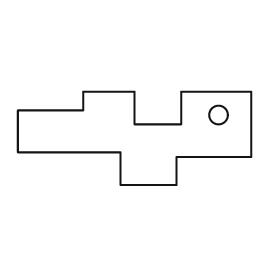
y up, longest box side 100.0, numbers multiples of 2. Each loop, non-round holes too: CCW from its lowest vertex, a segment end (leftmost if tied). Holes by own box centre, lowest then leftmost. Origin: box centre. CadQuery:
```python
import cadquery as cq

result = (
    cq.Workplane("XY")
    .moveTo(-6.0, -20.0)
    .lineTo(18.0, -20.0)
    .lineTo(18.0, -8.0)
    .lineTo(50.0, -8.0)
    .lineTo(50.0, 20.0)
    .lineTo(20.0, 20.0)
    .lineTo(20.0, 6.0)
    .lineTo(0.0, 6.0)
    .lineTo(0.0, 20.0)
    .lineTo(-22.0, 20.0)
    .lineTo(-22.0, 12.0)
    .lineTo(-50.0, 12.0)
    .lineTo(-50.0, -6.0)
    .lineTo(-6.0, -6.0)
    .close()
    .moveTo(36.0, 10.0)
    .circle(4.0)
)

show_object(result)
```